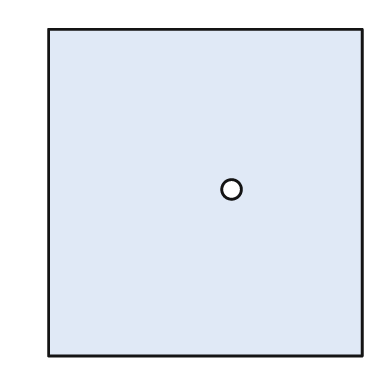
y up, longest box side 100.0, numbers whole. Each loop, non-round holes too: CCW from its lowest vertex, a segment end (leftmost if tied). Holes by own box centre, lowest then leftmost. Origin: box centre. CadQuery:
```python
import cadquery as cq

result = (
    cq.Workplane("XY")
    .moveTo(-48.0, -50.0)
    .lineTo(48.0, -50.0)
    .lineTo(48.0, 50.0)
    .lineTo(-48.0, 50.0)
    .close()
    .moveTo(8.0, 1.0)
    .circle(3.0)
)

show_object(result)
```